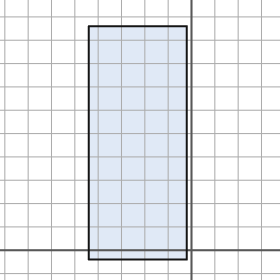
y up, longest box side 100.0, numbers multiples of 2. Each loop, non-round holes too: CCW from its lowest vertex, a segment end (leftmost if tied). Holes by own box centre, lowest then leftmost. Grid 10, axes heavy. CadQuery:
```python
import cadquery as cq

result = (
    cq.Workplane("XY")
    .moveTo(-44.0, -4.0)
    .lineTo(-2.0, -4.0)
    .lineTo(-2.0, 96.0)
    .lineTo(-44.0, 96.0)
    .close()
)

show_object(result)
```